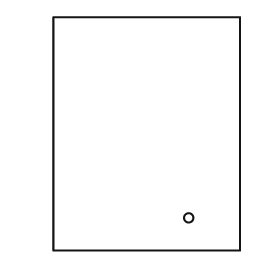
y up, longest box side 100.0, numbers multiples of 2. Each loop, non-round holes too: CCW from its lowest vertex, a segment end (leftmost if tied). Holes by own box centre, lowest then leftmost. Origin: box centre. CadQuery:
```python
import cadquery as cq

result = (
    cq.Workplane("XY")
    .moveTo(-40.0, -50.0)
    .lineTo(40.0, -50.0)
    .lineTo(40.0, 50.0)
    .lineTo(-40.0, 50.0)
    .close()
    .moveTo(18.0, -36.0)
    .circle(2.0)
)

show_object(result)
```